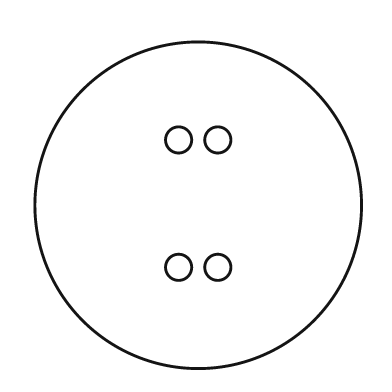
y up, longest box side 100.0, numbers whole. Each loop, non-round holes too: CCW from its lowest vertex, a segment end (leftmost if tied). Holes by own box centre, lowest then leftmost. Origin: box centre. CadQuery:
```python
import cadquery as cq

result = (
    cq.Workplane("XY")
    .moveTo(0.0, 0.0)
    .circle(50.0)
    .moveTo(-6.0, -19.0)
    .circle(4.0)
    .moveTo(6.0, -19.0)
    .circle(4.0)
    .moveTo(-6.0, 20.0)
    .circle(4.0)
    .moveTo(6.0, 20.0)
    .circle(4.0)
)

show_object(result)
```